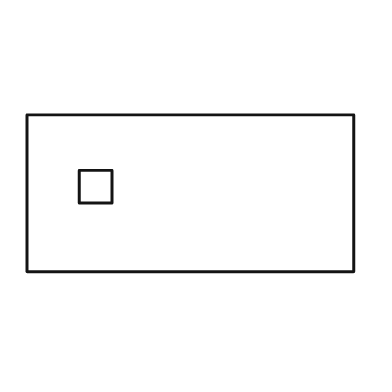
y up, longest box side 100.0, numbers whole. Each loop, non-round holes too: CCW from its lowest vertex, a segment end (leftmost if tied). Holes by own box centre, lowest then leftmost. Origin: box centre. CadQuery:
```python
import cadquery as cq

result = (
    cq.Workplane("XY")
    .moveTo(-50.0, -24.0)
    .lineTo(50.0, -24.0)
    .lineTo(50.0, 24.0)
    .lineTo(-50.0, 24.0)
    .close()
    .moveTo(-34.0, -3.0)
    .lineTo(-24.0, -3.0)
    .lineTo(-24.0, 7.0)
    .lineTo(-34.0, 7.0)
    .close()
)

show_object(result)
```